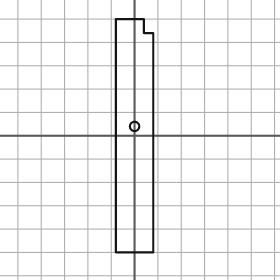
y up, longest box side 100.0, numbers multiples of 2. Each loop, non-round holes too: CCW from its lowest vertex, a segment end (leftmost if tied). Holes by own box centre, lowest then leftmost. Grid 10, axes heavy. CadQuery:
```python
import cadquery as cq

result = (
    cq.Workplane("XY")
    .moveTo(-8.0, -50.0)
    .lineTo(8.0, -50.0)
    .lineTo(8.0, 44.0)
    .lineTo(4.0, 44.0)
    .lineTo(4.0, 50.0)
    .lineTo(-8.0, 50.0)
    .close()
    .moveTo(0.0, 4.0)
    .circle(2.0)
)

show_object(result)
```